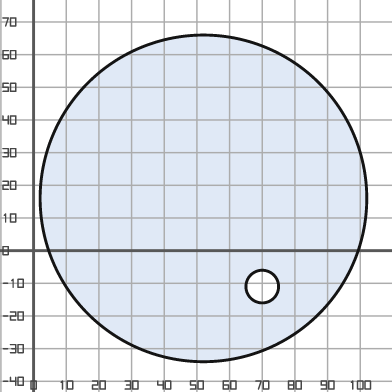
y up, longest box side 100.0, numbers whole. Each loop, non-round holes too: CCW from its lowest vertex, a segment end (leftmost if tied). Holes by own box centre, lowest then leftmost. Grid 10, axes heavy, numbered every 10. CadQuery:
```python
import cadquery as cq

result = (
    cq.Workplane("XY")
    .moveTo(52.0, 16.0)
    .circle(50.0)
    .moveTo(70.0, -11.0)
    .circle(5.0)
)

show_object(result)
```